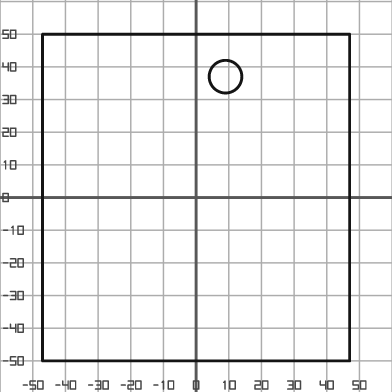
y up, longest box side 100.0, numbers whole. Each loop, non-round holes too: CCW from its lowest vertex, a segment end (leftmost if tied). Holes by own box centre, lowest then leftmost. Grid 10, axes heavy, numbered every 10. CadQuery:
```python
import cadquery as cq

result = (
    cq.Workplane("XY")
    .moveTo(-47.0, -50.0)
    .lineTo(47.0, -50.0)
    .lineTo(47.0, 50.0)
    .lineTo(-47.0, 50.0)
    .close()
    .moveTo(9.0, 37.0)
    .circle(5.0)
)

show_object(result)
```